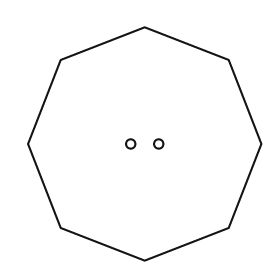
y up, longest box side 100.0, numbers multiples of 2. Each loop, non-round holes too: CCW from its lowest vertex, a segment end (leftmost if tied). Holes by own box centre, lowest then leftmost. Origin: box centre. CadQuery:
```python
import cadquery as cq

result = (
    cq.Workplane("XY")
    .moveTo(0.0, -50.0)
    .lineTo(36.0, -36.0)
    .lineTo(50.0, 0.0)
    .lineTo(36.0, 36.0)
    .lineTo(0.0, 50.0)
    .lineTo(-36.0, 36.0)
    .lineTo(-50.0, 0.0)
    .lineTo(-36.0, -36.0)
    .close()
    .moveTo(-6.0, 0.0)
    .circle(2.0)
    .moveTo(6.0, 0.0)
    .circle(2.0)
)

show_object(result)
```